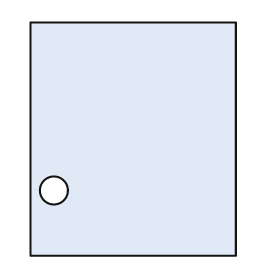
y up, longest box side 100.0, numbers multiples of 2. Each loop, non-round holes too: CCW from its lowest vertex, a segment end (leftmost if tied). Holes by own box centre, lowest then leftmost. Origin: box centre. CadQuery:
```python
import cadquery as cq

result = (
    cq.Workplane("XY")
    .moveTo(-44.0, -50.0)
    .lineTo(44.0, -50.0)
    .lineTo(44.0, 50.0)
    .lineTo(-44.0, 50.0)
    .close()
    .moveTo(-34.0, -22.0)
    .circle(6.0)
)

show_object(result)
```